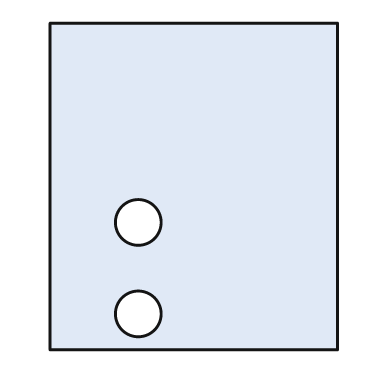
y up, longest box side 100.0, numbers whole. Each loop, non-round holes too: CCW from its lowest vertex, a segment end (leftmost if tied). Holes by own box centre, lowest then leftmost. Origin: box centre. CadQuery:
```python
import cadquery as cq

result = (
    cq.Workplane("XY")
    .moveTo(-44.0, -50.0)
    .lineTo(44.0, -50.0)
    .lineTo(44.0, 50.0)
    .lineTo(-44.0, 50.0)
    .close()
    .moveTo(-17.0, -39.0)
    .circle(7.0)
    .moveTo(-17.0, -11.0)
    .circle(7.0)
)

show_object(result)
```